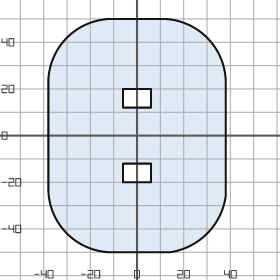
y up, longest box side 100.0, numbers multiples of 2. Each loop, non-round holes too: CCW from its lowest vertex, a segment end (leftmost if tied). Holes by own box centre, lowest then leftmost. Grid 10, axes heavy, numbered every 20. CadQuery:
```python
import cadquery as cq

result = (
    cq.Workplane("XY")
    .moveTo(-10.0, -50.0)
    .lineTo(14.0, -50.0)
    .threePointArc((30.0, -42.0), (38.0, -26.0))
    .lineTo(38.0, 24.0)
    .threePointArc((30.0, 42.0), (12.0, 50.0))
    .lineTo(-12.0, 50.0)
    .threePointArc((-30.0, 42.0), (-38.0, 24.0))
    .lineTo(-38.0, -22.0)
    .threePointArc((-30.0, -42.0), (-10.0, -50.0))
    .close()
    .moveTo(-6.0, -20.0)
    .lineTo(6.0, -20.0)
    .lineTo(6.0, -12.0)
    .lineTo(-6.0, -12.0)
    .close()
    .moveTo(-6.0, 12.0)
    .lineTo(6.0, 12.0)
    .lineTo(6.0, 20.0)
    .lineTo(-6.0, 20.0)
    .close()
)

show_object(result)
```